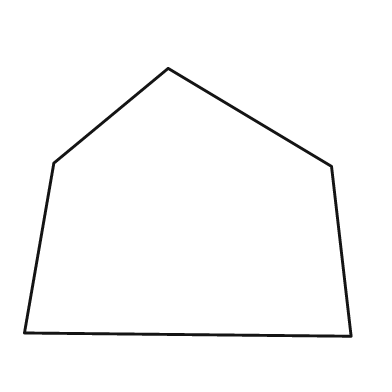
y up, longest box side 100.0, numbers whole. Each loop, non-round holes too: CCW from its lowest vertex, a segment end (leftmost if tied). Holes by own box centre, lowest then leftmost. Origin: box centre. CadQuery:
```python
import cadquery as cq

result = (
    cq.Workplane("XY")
    .moveTo(50.0, -41.0)
    .lineTo(44.0, 11.0)
    .lineTo(-6.0, 41.0)
    .lineTo(-41.0, 12.0)
    .lineTo(-50.0, -40.0)
    .close()
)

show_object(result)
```